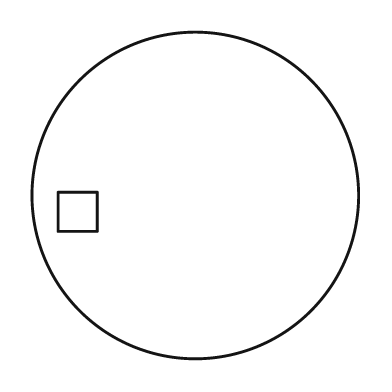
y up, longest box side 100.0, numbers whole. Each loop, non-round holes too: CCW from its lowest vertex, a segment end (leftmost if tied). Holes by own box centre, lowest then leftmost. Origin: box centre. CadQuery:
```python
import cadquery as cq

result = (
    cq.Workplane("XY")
    .moveTo(0.0, 0.0)
    .circle(50.0)
    .moveTo(-42.0, -11.0)
    .lineTo(-30.0, -11.0)
    .lineTo(-30.0, 1.0)
    .lineTo(-42.0, 1.0)
    .close()
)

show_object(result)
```